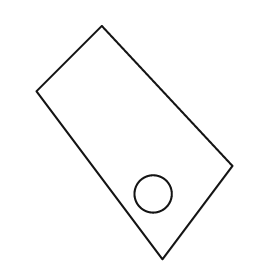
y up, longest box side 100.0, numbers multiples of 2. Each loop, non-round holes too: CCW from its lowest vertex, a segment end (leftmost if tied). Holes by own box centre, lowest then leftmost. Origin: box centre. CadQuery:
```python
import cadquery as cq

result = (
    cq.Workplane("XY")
    .moveTo(12.0, -50.0)
    .lineTo(42.0, -10.0)
    .lineTo(-14.0, 50.0)
    .lineTo(-42.0, 22.0)
    .close()
    .moveTo(8.0, -22.0)
    .circle(8.0)
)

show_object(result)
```